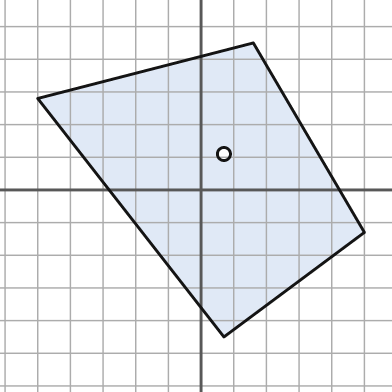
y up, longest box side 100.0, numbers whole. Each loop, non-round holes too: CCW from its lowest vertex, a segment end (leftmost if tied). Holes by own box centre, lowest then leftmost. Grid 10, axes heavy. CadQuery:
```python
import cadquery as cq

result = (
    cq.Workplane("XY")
    .moveTo(7.0, -45.0)
    .lineTo(50.0, -13.0)
    .lineTo(16.0, 45.0)
    .lineTo(-50.0, 28.0)
    .close()
    .moveTo(7.0, 11.0)
    .circle(2.0)
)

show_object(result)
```